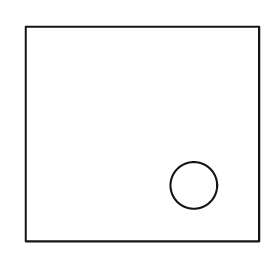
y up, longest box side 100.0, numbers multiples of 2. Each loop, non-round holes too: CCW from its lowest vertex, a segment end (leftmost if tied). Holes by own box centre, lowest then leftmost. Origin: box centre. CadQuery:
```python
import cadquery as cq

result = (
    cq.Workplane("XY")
    .moveTo(-50.0, -46.0)
    .lineTo(50.0, -46.0)
    .lineTo(50.0, 46.0)
    .lineTo(-50.0, 46.0)
    .close()
    .moveTo(22.0, -22.0)
    .circle(10.0)
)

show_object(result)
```